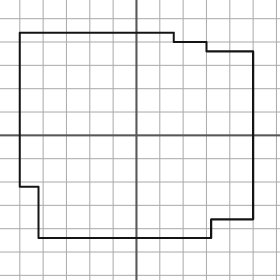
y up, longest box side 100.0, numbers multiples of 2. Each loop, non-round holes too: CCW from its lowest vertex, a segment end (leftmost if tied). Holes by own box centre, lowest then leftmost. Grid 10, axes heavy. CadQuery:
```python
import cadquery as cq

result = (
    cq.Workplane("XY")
    .moveTo(-42.0, -44.0)
    .lineTo(32.0, -44.0)
    .lineTo(32.0, -36.0)
    .lineTo(50.0, -36.0)
    .lineTo(50.0, 36.0)
    .lineTo(30.0, 36.0)
    .lineTo(30.0, 40.0)
    .lineTo(16.0, 40.0)
    .lineTo(16.0, 44.0)
    .lineTo(-50.0, 44.0)
    .lineTo(-50.0, -22.0)
    .lineTo(-42.0, -22.0)
    .close()
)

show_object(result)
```